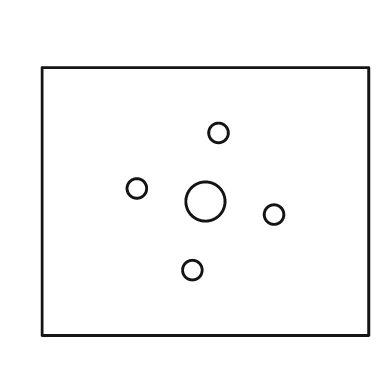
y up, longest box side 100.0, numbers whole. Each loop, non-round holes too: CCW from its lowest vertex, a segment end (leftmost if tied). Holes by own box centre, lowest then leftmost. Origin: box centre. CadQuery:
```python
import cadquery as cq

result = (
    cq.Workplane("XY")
    .moveTo(-50.0, -41.0)
    .lineTo(50.0, -41.0)
    .lineTo(50.0, 41.0)
    .lineTo(-50.0, 41.0)
    .close()
    .moveTo(-4.0, -21.0)
    .circle(3.0)
    .moveTo(21.0, -4.0)
    .circle(3.0)
    .moveTo(0.0, 0.0)
    .circle(6.0)
    .moveTo(-21.0, 4.0)
    .circle(3.0)
    .moveTo(4.0, 21.0)
    .circle(3.0)
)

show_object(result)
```